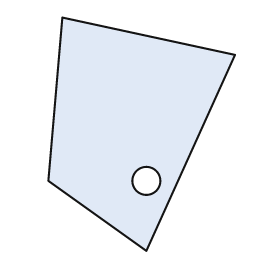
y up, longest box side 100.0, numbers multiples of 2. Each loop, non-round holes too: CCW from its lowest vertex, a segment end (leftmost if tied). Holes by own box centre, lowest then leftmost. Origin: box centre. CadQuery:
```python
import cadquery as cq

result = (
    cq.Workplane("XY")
    .moveTo(2.0, -50.0)
    .lineTo(40.0, 34.0)
    .lineTo(-34.0, 50.0)
    .lineTo(-40.0, -20.0)
    .close()
    .moveTo(2.0, -20.0)
    .circle(6.0)
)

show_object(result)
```